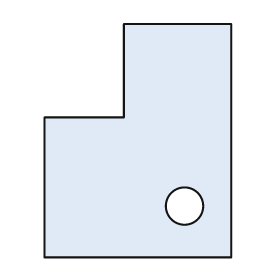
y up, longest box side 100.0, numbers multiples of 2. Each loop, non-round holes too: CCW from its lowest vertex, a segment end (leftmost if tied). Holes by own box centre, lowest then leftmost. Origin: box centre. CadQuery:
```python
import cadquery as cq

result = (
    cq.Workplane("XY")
    .moveTo(-40.0, -50.0)
    .lineTo(40.0, -50.0)
    .lineTo(40.0, 50.0)
    .lineTo(-6.0, 50.0)
    .lineTo(-6.0, 10.0)
    .lineTo(-40.0, 10.0)
    .close()
    .moveTo(20.0, -28.0)
    .circle(8.0)
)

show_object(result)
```